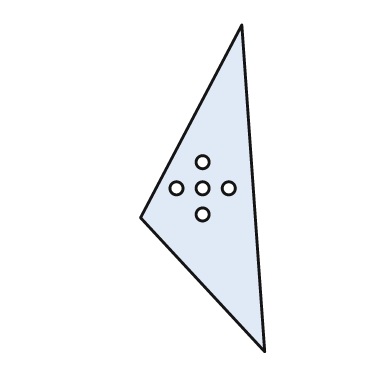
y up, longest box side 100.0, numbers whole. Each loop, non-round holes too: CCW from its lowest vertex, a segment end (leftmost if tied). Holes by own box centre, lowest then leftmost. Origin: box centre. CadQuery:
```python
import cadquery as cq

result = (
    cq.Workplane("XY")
    .moveTo(19.0, -50.0)
    .lineTo(12.0, 50.0)
    .lineTo(-19.0, -9.0)
    .close()
    .moveTo(0.0, -8.0)
    .circle(2.0)
    .moveTo(-8.0, 0.0)
    .circle(2.0)
    .moveTo(0.0, 0.0)
    .circle(2.0)
    .moveTo(8.0, 0.0)
    .circle(2.0)
    .moveTo(0.0, 8.0)
    .circle(2.0)
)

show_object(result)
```